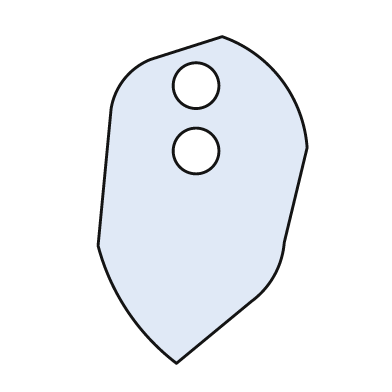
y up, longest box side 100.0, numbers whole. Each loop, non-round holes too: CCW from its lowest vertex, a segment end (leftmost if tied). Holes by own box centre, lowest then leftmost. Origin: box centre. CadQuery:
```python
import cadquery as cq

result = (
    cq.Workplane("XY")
    .moveTo(-8.0, -50.0)
    .lineTo(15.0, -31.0)
    .threePointArc((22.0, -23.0), (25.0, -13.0))
    .lineTo(32.0, 16.0)
    .threePointArc((24.0, 37.0), (6.0, 50.0))
    .lineTo(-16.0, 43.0)
    .threePointArc((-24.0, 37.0), (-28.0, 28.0))
    .lineTo(-32.0, -14.0)
    .threePointArc((-23.0, -34.0), (-8.0, -50.0))
    .close()
    .moveTo(-2.0, 15.0)
    .circle(7.0)
    .moveTo(-2.0, 35.0)
    .circle(7.0)
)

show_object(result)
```